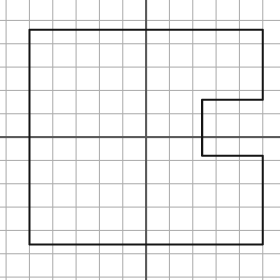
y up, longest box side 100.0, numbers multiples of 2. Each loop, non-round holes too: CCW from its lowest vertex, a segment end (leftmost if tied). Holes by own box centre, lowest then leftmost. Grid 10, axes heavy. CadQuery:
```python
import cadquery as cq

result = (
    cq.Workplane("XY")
    .moveTo(-50.0, -46.0)
    .lineTo(50.0, -46.0)
    .lineTo(50.0, -8.0)
    .lineTo(24.0, -8.0)
    .lineTo(24.0, 16.0)
    .lineTo(50.0, 16.0)
    .lineTo(50.0, 46.0)
    .lineTo(-50.0, 46.0)
    .close()
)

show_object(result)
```